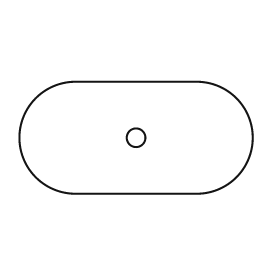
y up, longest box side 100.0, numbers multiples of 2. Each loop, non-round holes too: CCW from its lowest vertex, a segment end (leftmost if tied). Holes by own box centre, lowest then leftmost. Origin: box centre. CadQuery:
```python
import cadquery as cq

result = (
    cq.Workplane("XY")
    .moveTo(-26.0, -24.0)
    .lineTo(26.0, -24.0)
    .threePointArc((50.0, 0.0), (26.0, 24.0))
    .lineTo(-26.0, 24.0)
    .threePointArc((-50.0, 0.0), (-26.0, -24.0))
    .close()
    .moveTo(0.0, 0.0)
    .circle(4.0)
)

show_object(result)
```